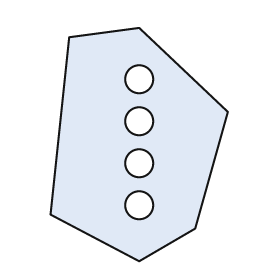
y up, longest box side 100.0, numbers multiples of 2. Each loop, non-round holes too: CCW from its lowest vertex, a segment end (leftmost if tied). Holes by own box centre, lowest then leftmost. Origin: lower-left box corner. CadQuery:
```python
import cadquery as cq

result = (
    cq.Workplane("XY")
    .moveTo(38.0, 0.0)
    .lineTo(62.0, 14.0)
    .lineTo(76.0, 64.0)
    .lineTo(38.0, 100.0)
    .lineTo(8.0, 96.0)
    .lineTo(0.0, 20.0)
    .close()
    .moveTo(38.0, 24.0)
    .circle(6.0)
    .moveTo(38.0, 42.0)
    .circle(6.0)
    .moveTo(38.0, 60.0)
    .circle(6.0)
    .moveTo(38.0, 78.0)
    .circle(6.0)
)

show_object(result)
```